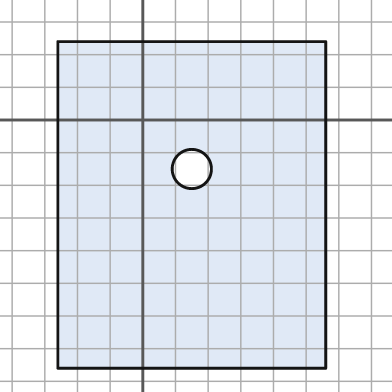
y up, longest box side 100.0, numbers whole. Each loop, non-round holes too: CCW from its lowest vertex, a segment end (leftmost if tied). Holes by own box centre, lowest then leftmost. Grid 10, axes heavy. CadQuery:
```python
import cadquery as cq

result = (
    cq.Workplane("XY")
    .moveTo(-26.0, -76.0)
    .lineTo(56.0, -76.0)
    .lineTo(56.0, 24.0)
    .lineTo(-26.0, 24.0)
    .close()
    .moveTo(15.0, -15.0)
    .circle(6.0)
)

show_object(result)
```